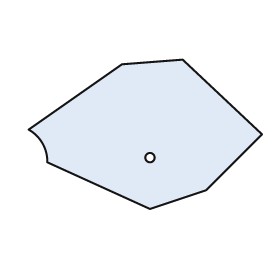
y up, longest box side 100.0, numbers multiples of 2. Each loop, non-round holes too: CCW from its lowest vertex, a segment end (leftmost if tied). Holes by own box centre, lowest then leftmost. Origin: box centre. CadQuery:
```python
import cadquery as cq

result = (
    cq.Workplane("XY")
    .moveTo(2.0, -32.0)
    .lineTo(26.0, -24.0)
    .lineTo(50.0, 0.0)
    .lineTo(16.0, 32.0)
    .lineTo(-10.0, 30.0)
    .lineTo(-50.0, 2.0)
    .threePointArc((-44.0, -4.0), (-42.0, -12.0))
    .close()
    .moveTo(2.0, -10.0)
    .circle(2.0)
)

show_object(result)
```